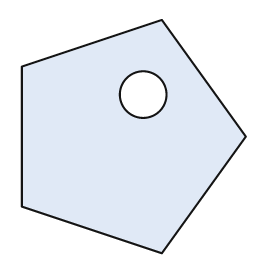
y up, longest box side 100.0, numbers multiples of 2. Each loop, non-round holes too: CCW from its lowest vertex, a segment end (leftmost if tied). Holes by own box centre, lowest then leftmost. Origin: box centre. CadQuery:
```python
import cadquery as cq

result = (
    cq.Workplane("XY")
    .moveTo(12.0, -50.0)
    .lineTo(48.0, 0.0)
    .lineTo(12.0, 50.0)
    .lineTo(-48.0, 30.0)
    .lineTo(-48.0, -30.0)
    .close()
    .moveTo(4.0, 18.0)
    .circle(10.0)
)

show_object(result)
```